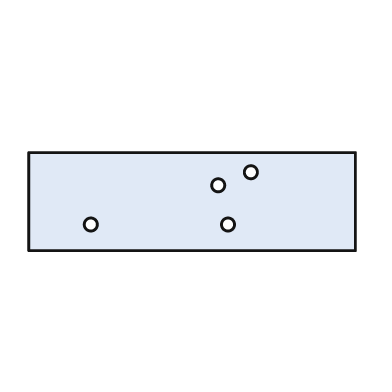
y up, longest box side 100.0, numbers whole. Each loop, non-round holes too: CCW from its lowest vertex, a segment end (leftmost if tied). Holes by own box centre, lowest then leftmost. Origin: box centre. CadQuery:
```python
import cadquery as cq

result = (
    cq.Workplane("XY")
    .moveTo(-50.0, -15.0)
    .lineTo(50.0, -15.0)
    .lineTo(50.0, 15.0)
    .lineTo(-50.0, 15.0)
    .close()
    .moveTo(-31.0, -7.0)
    .circle(2.0)
    .moveTo(11.0, -7.0)
    .circle(2.0)
    .moveTo(8.0, 5.0)
    .circle(2.0)
    .moveTo(18.0, 9.0)
    .circle(2.0)
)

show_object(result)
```